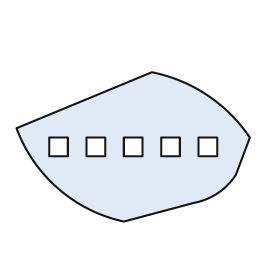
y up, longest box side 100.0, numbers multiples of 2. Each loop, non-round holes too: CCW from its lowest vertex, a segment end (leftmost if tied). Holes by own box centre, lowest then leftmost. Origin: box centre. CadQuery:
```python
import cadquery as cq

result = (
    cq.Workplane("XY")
    .moveTo(-4.0, -32.0)
    .lineTo(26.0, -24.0)
    .threePointArc((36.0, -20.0), (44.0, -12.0))
    .lineTo(50.0, 4.0)
    .threePointArc((32.0, 22.0), (8.0, 32.0))
    .lineTo(-50.0, 8.0)
    .threePointArc((-32.0, -18.0), (-4.0, -32.0))
    .close()
    .moveTo(-36.0, -4.0)
    .lineTo(-28.0, -4.0)
    .lineTo(-28.0, 4.0)
    .lineTo(-36.0, 4.0)
    .close()
    .moveTo(-20.0, -4.0)
    .lineTo(-12.0, -4.0)
    .lineTo(-12.0, 4.0)
    .lineTo(-20.0, 4.0)
    .close()
    .moveTo(-4.0, -4.0)
    .lineTo(4.0, -4.0)
    .lineTo(4.0, 4.0)
    .lineTo(-4.0, 4.0)
    .close()
    .moveTo(12.0, -4.0)
    .lineTo(20.0, -4.0)
    .lineTo(20.0, 4.0)
    .lineTo(12.0, 4.0)
    .close()
    .moveTo(28.0, -4.0)
    .lineTo(36.0, -4.0)
    .lineTo(36.0, 4.0)
    .lineTo(28.0, 4.0)
    .close()
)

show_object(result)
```